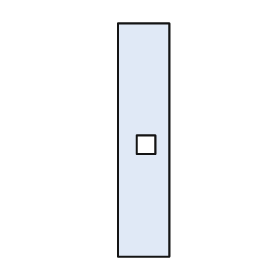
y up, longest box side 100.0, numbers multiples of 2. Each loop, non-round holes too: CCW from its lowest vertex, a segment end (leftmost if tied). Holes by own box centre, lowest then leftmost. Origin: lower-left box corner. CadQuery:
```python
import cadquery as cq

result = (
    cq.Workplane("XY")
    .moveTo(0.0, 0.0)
    .lineTo(22.0, 0.0)
    .lineTo(22.0, 100.0)
    .lineTo(0.0, 100.0)
    .close()
    .moveTo(8.0, 44.0)
    .lineTo(16.0, 44.0)
    .lineTo(16.0, 52.0)
    .lineTo(8.0, 52.0)
    .close()
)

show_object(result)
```